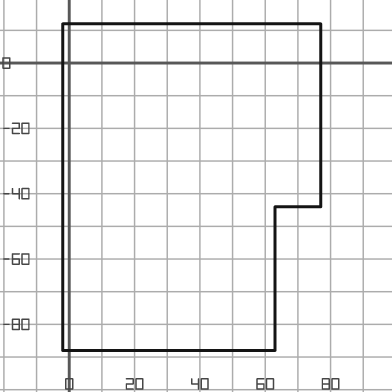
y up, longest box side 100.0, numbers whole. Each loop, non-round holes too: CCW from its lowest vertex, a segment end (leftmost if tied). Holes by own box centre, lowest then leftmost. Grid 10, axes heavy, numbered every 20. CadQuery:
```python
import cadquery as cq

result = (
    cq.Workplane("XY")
    .moveTo(-2.0, -88.0)
    .lineTo(63.0, -88.0)
    .lineTo(63.0, -44.0)
    .lineTo(77.0, -44.0)
    .lineTo(77.0, 12.0)
    .lineTo(-2.0, 12.0)
    .close()
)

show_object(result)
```